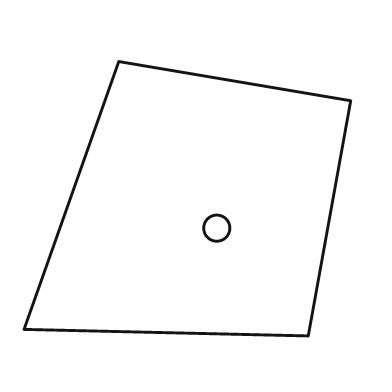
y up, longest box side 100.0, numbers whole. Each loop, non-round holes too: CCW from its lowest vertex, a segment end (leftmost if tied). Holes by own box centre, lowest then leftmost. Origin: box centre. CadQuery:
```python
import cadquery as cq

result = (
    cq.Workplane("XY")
    .moveTo(37.0, -42.0)
    .lineTo(50.0, 30.0)
    .lineTo(-21.0, 42.0)
    .lineTo(-50.0, -40.0)
    .close()
    .moveTo(9.0, -9.0)
    .circle(4.0)
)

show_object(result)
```